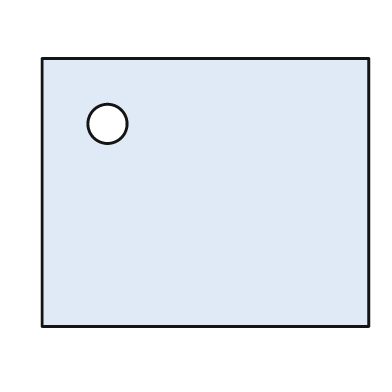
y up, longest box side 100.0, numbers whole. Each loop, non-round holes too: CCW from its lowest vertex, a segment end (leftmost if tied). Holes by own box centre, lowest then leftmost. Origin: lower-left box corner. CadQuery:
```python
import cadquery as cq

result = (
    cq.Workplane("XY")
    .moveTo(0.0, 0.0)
    .lineTo(100.0, 0.0)
    .lineTo(100.0, 82.0)
    .lineTo(0.0, 82.0)
    .close()
    .moveTo(20.0, 62.0)
    .circle(6.0)
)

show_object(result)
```